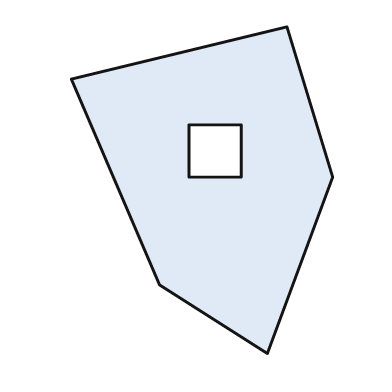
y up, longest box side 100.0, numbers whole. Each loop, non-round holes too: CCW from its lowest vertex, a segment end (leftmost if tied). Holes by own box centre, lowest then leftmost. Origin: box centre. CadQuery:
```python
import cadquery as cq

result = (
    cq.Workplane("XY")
    .moveTo(20.0, -50.0)
    .lineTo(40.0, 4.0)
    .lineTo(26.0, 50.0)
    .lineTo(-40.0, 34.0)
    .lineTo(-13.0, -29.0)
    .close()
    .moveTo(-4.0, 4.0)
    .lineTo(12.0, 4.0)
    .lineTo(12.0, 20.0)
    .lineTo(-4.0, 20.0)
    .close()
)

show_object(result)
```